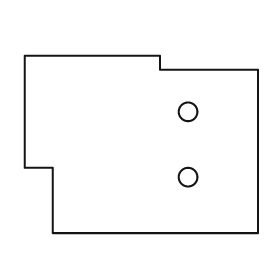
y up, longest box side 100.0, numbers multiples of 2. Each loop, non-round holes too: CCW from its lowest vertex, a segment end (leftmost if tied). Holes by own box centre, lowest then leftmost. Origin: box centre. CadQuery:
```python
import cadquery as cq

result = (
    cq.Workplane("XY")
    .moveTo(-38.0, -38.0)
    .lineTo(50.0, -38.0)
    .lineTo(50.0, 32.0)
    .lineTo(8.0, 32.0)
    .lineTo(8.0, 38.0)
    .lineTo(-50.0, 38.0)
    .lineTo(-50.0, -10.0)
    .lineTo(-38.0, -10.0)
    .close()
    .moveTo(20.0, -14.0)
    .circle(4.0)
    .moveTo(20.0, 14.0)
    .circle(4.0)
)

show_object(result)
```